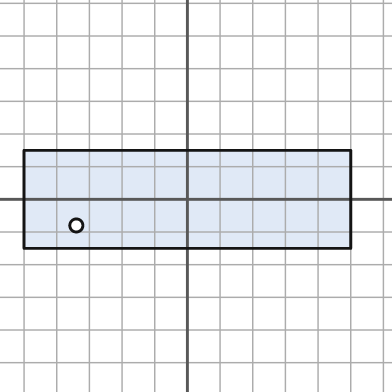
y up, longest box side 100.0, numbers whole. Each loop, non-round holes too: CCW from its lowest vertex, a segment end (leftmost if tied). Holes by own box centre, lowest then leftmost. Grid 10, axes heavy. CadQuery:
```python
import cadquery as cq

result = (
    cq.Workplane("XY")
    .moveTo(-50.0, -15.0)
    .lineTo(50.0, -15.0)
    .lineTo(50.0, 15.0)
    .lineTo(-50.0, 15.0)
    .close()
    .moveTo(-34.0, -8.0)
    .circle(2.0)
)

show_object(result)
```